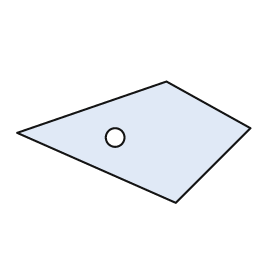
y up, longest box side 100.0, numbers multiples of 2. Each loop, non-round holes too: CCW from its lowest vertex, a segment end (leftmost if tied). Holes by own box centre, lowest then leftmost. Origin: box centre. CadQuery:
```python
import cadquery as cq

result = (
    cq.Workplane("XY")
    .moveTo(18.0, -26.0)
    .lineTo(50.0, 6.0)
    .lineTo(14.0, 26.0)
    .lineTo(-50.0, 4.0)
    .close()
    .moveTo(-8.0, 2.0)
    .circle(4.0)
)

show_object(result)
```